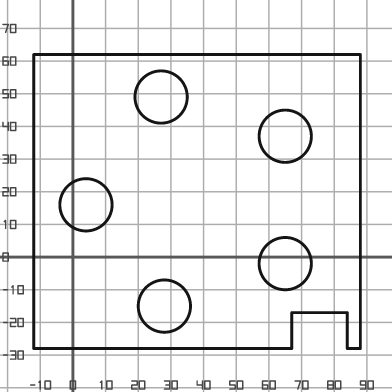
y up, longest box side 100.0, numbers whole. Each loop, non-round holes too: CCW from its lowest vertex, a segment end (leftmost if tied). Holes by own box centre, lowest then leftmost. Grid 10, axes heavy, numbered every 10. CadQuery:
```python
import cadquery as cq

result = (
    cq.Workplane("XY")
    .moveTo(-12.0, -28.0)
    .lineTo(67.0, -28.0)
    .lineTo(67.0, -17.0)
    .lineTo(84.0, -17.0)
    .lineTo(84.0, -28.0)
    .lineTo(88.0, -28.0)
    .lineTo(88.0, 62.0)
    .lineTo(-12.0, 62.0)
    .close()
    .moveTo(28.0, -15.0)
    .circle(8.0)
    .moveTo(65.0, -2.0)
    .circle(8.0)
    .moveTo(4.0, 16.0)
    .circle(8.0)
    .moveTo(65.0, 37.0)
    .circle(8.0)
    .moveTo(27.0, 49.0)
    .circle(8.0)
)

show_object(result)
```